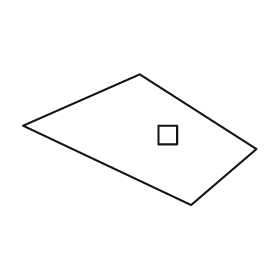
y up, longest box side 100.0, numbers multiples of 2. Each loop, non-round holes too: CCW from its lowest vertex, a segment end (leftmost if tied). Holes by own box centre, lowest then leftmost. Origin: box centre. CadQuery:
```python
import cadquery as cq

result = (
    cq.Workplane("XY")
    .moveTo(22.0, -28.0)
    .lineTo(50.0, -4.0)
    .lineTo(0.0, 28.0)
    .lineTo(-50.0, 6.0)
    .close()
    .moveTo(8.0, -2.0)
    .lineTo(16.0, -2.0)
    .lineTo(16.0, 6.0)
    .lineTo(8.0, 6.0)
    .close()
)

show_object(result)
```